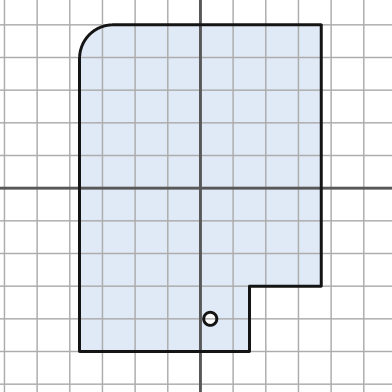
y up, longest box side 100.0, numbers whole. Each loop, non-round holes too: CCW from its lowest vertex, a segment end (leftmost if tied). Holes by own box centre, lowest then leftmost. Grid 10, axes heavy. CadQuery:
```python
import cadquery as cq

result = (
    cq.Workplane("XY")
    .moveTo(-37.0, -50.0)
    .lineTo(15.0, -50.0)
    .lineTo(15.0, -30.0)
    .lineTo(37.0, -30.0)
    .lineTo(37.0, 50.0)
    .lineTo(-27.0, 50.0)
    .threePointArc((-34.0, 47.0), (-37.0, 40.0))
    .close()
    .moveTo(3.0, -40.0)
    .circle(2.0)
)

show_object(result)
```